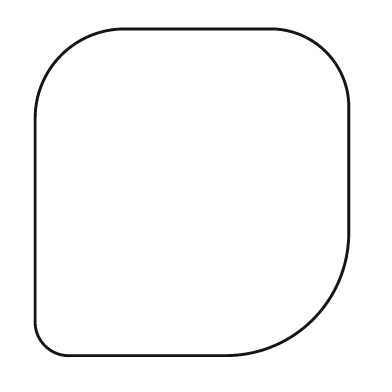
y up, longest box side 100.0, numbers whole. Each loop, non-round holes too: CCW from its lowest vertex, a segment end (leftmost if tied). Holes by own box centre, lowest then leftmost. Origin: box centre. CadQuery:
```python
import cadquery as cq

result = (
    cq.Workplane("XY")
    .moveTo(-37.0, -50.0)
    .lineTo(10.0, -50.0)
    .threePointArc((37.0, -39.0), (48.0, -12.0))
    .lineTo(48.0, 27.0)
    .threePointArc((41.0, 43.0), (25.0, 50.0))
    .lineTo(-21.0, 50.0)
    .threePointArc((-40.0, 42.0), (-48.0, 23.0))
    .lineTo(-48.0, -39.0)
    .threePointArc((-45.0, -47.0), (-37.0, -50.0))
    .close()
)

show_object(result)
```